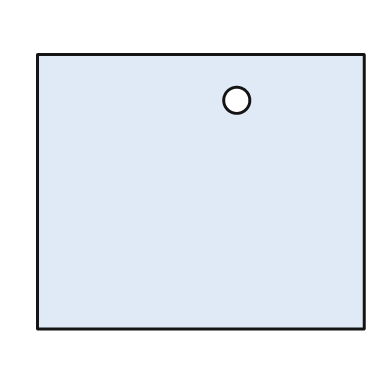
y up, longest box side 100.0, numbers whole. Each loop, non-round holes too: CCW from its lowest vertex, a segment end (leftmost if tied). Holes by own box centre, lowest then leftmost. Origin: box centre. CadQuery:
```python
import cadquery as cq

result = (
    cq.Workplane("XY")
    .moveTo(-50.0, -42.0)
    .lineTo(50.0, -42.0)
    .lineTo(50.0, 42.0)
    .lineTo(-50.0, 42.0)
    .close()
    .moveTo(11.0, 28.0)
    .circle(4.0)
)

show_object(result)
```